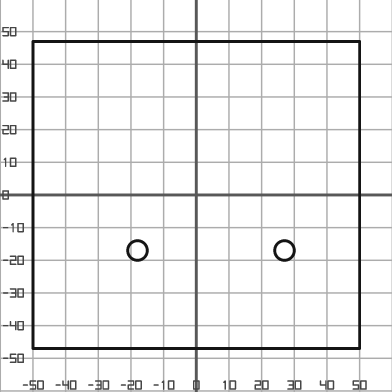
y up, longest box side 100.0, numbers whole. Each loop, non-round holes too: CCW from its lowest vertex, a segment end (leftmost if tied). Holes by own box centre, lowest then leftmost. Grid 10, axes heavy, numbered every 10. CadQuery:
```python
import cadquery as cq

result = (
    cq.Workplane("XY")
    .moveTo(-50.0, -47.0)
    .lineTo(50.0, -47.0)
    .lineTo(50.0, 47.0)
    .lineTo(-50.0, 47.0)
    .close()
    .moveTo(-18.0, -17.0)
    .circle(3.0)
    .moveTo(27.0, -17.0)
    .circle(3.0)
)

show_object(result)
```